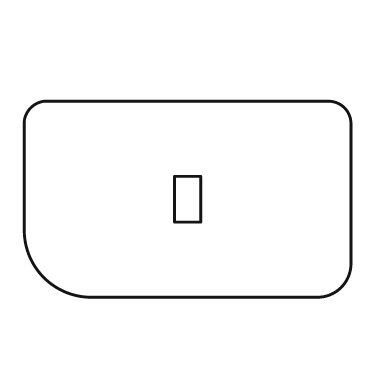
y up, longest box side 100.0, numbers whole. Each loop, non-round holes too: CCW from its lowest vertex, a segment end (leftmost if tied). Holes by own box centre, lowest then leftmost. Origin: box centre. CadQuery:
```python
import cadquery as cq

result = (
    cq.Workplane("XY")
    .moveTo(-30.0, -30.0)
    .lineTo(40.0, -30.0)
    .threePointArc((47.0, -27.0), (50.0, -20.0))
    .lineTo(50.0, 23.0)
    .threePointArc((48.0, 28.0), (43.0, 30.0))
    .lineTo(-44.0, 30.0)
    .threePointArc((-48.0, 28.0), (-50.0, 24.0))
    .lineTo(-50.0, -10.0)
    .threePointArc((-44.0, -24.0), (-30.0, -30.0))
    .close()
    .moveTo(-4.0, -7.0)
    .lineTo(4.0, -7.0)
    .lineTo(4.0, 7.0)
    .lineTo(-4.0, 7.0)
    .close()
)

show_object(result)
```